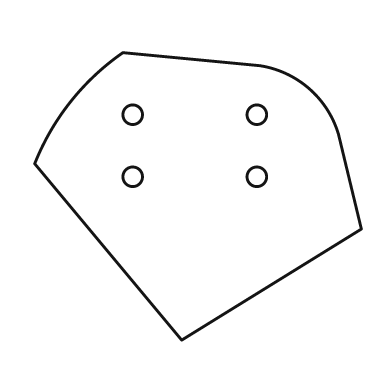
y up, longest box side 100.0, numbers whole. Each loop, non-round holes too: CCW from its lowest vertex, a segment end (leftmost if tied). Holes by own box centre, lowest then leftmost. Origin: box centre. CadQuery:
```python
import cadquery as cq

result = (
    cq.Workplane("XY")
    .moveTo(-5.0, -44.0)
    .lineTo(50.0, -10.0)
    .lineTo(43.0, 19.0)
    .threePointArc((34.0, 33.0), (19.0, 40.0))
    .lineTo(-23.0, 44.0)
    .threePointArc((-39.0, 29.0), (-50.0, 10.0))
    .close()
    .moveTo(-20.0, 6.0)
    .circle(3.0)
    .moveTo(18.0, 6.0)
    .circle(3.0)
    .moveTo(-20.0, 25.0)
    .circle(3.0)
    .moveTo(18.0, 25.0)
    .circle(3.0)
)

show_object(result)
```